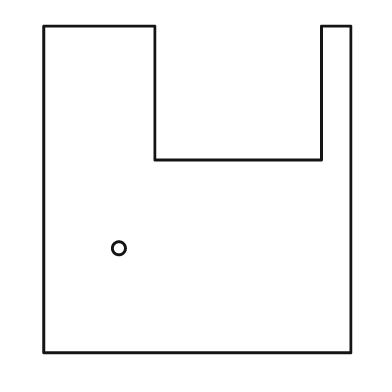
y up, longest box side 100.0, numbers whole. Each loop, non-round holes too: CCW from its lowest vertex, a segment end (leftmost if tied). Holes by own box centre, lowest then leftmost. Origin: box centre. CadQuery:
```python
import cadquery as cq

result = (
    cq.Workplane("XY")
    .moveTo(-47.0, -50.0)
    .lineTo(47.0, -50.0)
    .lineTo(47.0, 50.0)
    .lineTo(38.0, 50.0)
    .lineTo(38.0, 9.0)
    .lineTo(-13.0, 9.0)
    .lineTo(-13.0, 50.0)
    .lineTo(-47.0, 50.0)
    .close()
    .moveTo(-24.0, -18.0)
    .circle(2.0)
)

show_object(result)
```